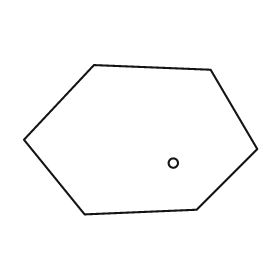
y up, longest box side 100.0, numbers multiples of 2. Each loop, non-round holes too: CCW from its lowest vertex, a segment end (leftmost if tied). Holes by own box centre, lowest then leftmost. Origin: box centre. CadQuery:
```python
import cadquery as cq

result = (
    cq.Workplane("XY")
    .moveTo(-24.0, -32.0)
    .lineTo(24.0, -30.0)
    .lineTo(50.0, -4.0)
    .lineTo(30.0, 30.0)
    .lineTo(-20.0, 32.0)
    .lineTo(-50.0, 0.0)
    .close()
    .moveTo(14.0, -10.0)
    .circle(2.0)
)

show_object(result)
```